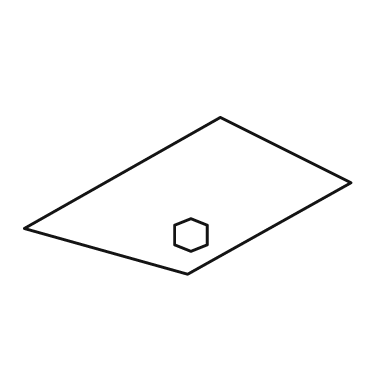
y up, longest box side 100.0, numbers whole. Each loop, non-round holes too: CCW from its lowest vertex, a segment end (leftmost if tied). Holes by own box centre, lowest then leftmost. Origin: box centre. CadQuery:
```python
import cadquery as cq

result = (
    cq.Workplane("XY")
    .moveTo(0.0, -24.0)
    .lineTo(50.0, 4.0)
    .lineTo(10.0, 24.0)
    .lineTo(-50.0, -10.0)
    .close()
    .moveTo(1.0, -17.0)
    .lineTo(6.0, -15.0)
    .lineTo(6.0, -9.0)
    .lineTo(1.0, -7.0)
    .lineTo(-4.0, -9.0)
    .lineTo(-4.0, -15.0)
    .close()
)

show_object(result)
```